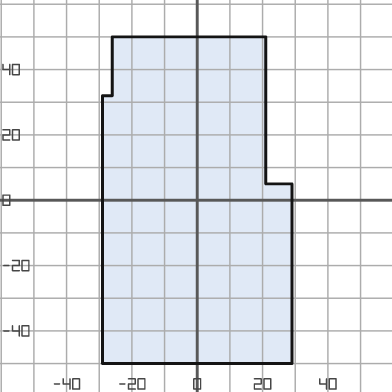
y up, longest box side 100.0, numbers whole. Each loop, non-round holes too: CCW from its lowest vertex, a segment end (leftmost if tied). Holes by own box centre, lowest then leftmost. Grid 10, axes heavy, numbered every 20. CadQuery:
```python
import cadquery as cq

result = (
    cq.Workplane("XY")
    .moveTo(-29.0, -50.0)
    .lineTo(29.0, -50.0)
    .lineTo(29.0, 5.0)
    .lineTo(21.0, 5.0)
    .lineTo(21.0, 50.0)
    .lineTo(-26.0, 50.0)
    .lineTo(-26.0, 32.0)
    .lineTo(-29.0, 32.0)
    .close()
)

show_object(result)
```